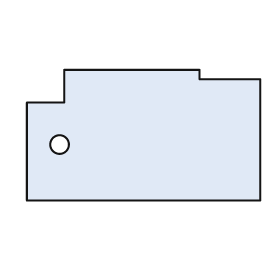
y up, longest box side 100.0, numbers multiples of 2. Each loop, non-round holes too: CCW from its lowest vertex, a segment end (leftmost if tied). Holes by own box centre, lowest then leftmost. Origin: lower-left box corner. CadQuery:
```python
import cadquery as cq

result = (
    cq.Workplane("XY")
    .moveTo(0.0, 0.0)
    .lineTo(100.0, 0.0)
    .lineTo(100.0, 52.0)
    .lineTo(74.0, 52.0)
    .lineTo(74.0, 56.0)
    .lineTo(16.0, 56.0)
    .lineTo(16.0, 42.0)
    .lineTo(0.0, 42.0)
    .close()
    .moveTo(14.0, 24.0)
    .circle(4.0)
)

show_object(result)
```